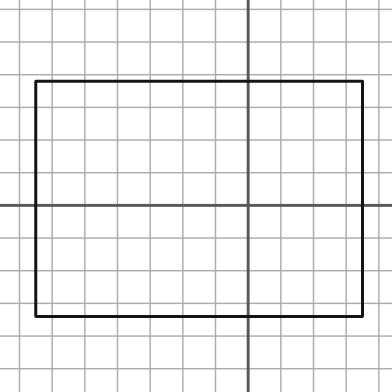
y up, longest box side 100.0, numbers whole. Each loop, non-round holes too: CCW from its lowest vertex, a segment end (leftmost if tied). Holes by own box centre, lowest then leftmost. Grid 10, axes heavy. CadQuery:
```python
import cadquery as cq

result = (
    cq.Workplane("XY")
    .moveTo(-65.0, -34.0)
    .lineTo(35.0, -34.0)
    .lineTo(35.0, 38.0)
    .lineTo(-65.0, 38.0)
    .close()
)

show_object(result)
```